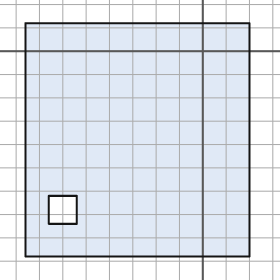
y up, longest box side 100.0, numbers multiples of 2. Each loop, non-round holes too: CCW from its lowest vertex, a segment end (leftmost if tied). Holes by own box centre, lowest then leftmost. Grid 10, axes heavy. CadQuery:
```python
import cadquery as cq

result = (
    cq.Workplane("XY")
    .moveTo(-76.0, -88.0)
    .lineTo(20.0, -88.0)
    .lineTo(20.0, 12.0)
    .lineTo(-76.0, 12.0)
    .close()
    .moveTo(-66.0, -74.0)
    .lineTo(-54.0, -74.0)
    .lineTo(-54.0, -62.0)
    .lineTo(-66.0, -62.0)
    .close()
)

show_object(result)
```